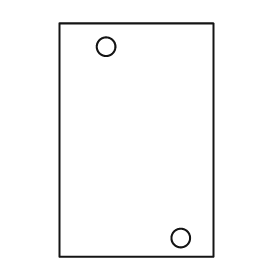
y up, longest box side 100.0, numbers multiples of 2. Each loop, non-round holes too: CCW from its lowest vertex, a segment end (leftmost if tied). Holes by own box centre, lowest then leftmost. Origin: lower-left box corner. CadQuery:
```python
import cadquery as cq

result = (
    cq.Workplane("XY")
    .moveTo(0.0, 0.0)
    .lineTo(66.0, 0.0)
    .lineTo(66.0, 100.0)
    .lineTo(0.0, 100.0)
    .close()
    .moveTo(52.0, 8.0)
    .circle(4.0)
    .moveTo(20.0, 90.0)
    .circle(4.0)
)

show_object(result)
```